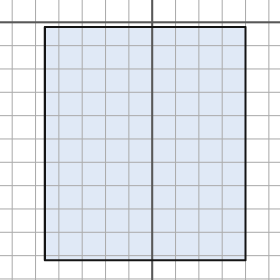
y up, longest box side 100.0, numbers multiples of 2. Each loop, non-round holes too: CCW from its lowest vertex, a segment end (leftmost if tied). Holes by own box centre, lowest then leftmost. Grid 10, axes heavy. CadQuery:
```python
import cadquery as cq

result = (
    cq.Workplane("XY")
    .moveTo(-46.0, -102.0)
    .lineTo(40.0, -102.0)
    .lineTo(40.0, -2.0)
    .lineTo(-46.0, -2.0)
    .close()
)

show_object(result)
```